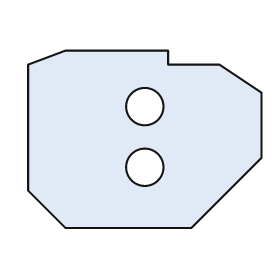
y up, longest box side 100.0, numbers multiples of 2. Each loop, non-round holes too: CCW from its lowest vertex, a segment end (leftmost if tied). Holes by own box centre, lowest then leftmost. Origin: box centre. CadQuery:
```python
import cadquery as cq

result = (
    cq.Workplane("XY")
    .moveTo(-34.0, -38.0)
    .lineTo(20.0, -38.0)
    .lineTo(50.0, -8.0)
    .lineTo(50.0, 20.0)
    .lineTo(32.0, 32.0)
    .lineTo(10.0, 32.0)
    .lineTo(10.0, 38.0)
    .lineTo(-34.0, 38.0)
    .lineTo(-50.0, 32.0)
    .lineTo(-50.0, -22.0)
    .close()
    .moveTo(0.0, -12.0)
    .circle(8.0)
    .moveTo(0.0, 14.0)
    .circle(8.0)
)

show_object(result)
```